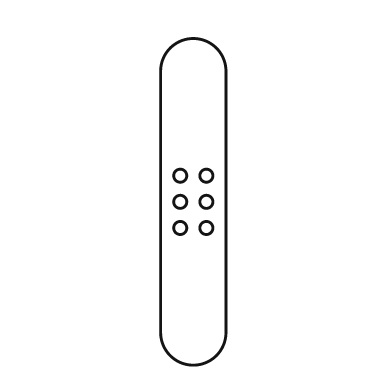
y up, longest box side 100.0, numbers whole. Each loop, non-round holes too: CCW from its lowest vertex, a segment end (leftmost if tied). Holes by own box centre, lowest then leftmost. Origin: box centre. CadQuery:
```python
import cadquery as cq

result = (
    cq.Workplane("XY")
    .moveTo(-10.0, -40.0)
    .threePointArc((0.0, -50.0), (10.0, -40.0))
    .lineTo(10.0, 40.0)
    .threePointArc((0.0, 50.0), (-10.0, 40.0))
    .close()
    .moveTo(-4.0, -8.0)
    .circle(2.0)
    .moveTo(4.0, -8.0)
    .circle(2.0)
    .moveTo(-4.0, 0.0)
    .circle(2.0)
    .moveTo(4.0, 0.0)
    .circle(2.0)
    .moveTo(-4.0, 8.0)
    .circle(2.0)
    .moveTo(4.0, 8.0)
    .circle(2.0)
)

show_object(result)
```